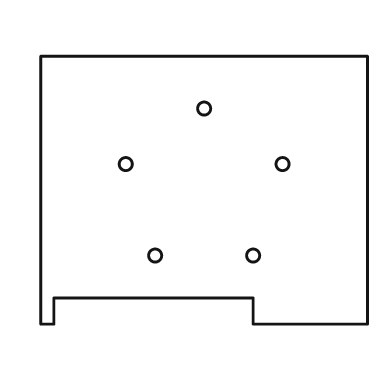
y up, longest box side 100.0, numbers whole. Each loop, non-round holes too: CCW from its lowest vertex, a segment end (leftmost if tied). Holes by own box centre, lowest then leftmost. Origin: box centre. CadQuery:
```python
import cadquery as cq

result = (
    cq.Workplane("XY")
    .moveTo(-50.0, -41.0)
    .lineTo(-46.0, -41.0)
    .lineTo(-46.0, -33.0)
    .lineTo(15.0, -33.0)
    .lineTo(15.0, -41.0)
    .lineTo(50.0, -41.0)
    .lineTo(50.0, 41.0)
    .lineTo(-50.0, 41.0)
    .close()
    .moveTo(-15.0, -20.0)
    .circle(2.0)
    .moveTo(15.0, -20.0)
    .circle(2.0)
    .moveTo(-24.0, 8.0)
    .circle(2.0)
    .moveTo(24.0, 8.0)
    .circle(2.0)
    .moveTo(0.0, 25.0)
    .circle(2.0)
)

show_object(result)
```